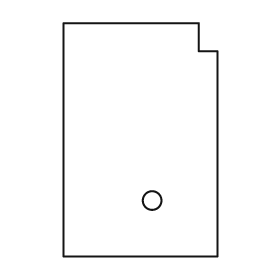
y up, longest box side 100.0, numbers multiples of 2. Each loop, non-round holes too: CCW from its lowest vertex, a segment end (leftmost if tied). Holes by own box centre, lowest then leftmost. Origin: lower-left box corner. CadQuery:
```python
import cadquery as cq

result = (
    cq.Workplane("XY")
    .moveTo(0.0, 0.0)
    .lineTo(66.0, 0.0)
    .lineTo(66.0, 88.0)
    .lineTo(58.0, 88.0)
    .lineTo(58.0, 100.0)
    .lineTo(0.0, 100.0)
    .close()
    .moveTo(38.0, 24.0)
    .circle(4.0)
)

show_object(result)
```